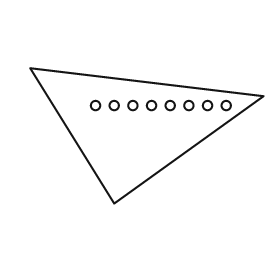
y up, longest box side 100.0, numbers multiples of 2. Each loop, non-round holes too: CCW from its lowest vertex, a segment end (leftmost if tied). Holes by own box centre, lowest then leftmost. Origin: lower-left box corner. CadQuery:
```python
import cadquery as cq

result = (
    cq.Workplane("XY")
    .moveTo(36.0, 0.0)
    .lineTo(100.0, 46.0)
    .lineTo(0.0, 58.0)
    .close()
    .moveTo(28.0, 42.0)
    .circle(2.0)
    .moveTo(36.0, 42.0)
    .circle(2.0)
    .moveTo(44.0, 42.0)
    .circle(2.0)
    .moveTo(52.0, 42.0)
    .circle(2.0)
    .moveTo(60.0, 42.0)
    .circle(2.0)
    .moveTo(68.0, 42.0)
    .circle(2.0)
    .moveTo(76.0, 42.0)
    .circle(2.0)
    .moveTo(84.0, 42.0)
    .circle(2.0)
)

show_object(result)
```